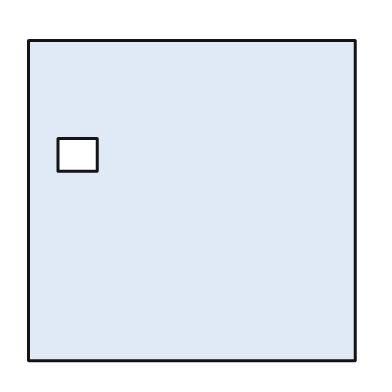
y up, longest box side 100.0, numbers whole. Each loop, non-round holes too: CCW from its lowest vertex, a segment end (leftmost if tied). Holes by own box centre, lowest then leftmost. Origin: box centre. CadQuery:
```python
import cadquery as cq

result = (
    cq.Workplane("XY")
    .moveTo(-50.0, -49.0)
    .lineTo(50.0, -49.0)
    .lineTo(50.0, 49.0)
    .lineTo(-50.0, 49.0)
    .close()
    .moveTo(-41.0, 9.0)
    .lineTo(-29.0, 9.0)
    .lineTo(-29.0, 19.0)
    .lineTo(-41.0, 19.0)
    .close()
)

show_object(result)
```